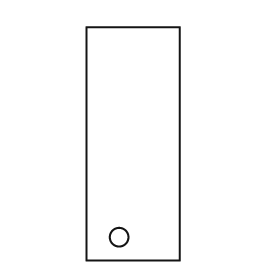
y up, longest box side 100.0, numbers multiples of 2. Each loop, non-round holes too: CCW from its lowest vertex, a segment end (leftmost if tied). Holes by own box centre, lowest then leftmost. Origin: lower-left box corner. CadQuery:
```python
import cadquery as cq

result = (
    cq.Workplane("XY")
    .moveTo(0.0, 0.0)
    .lineTo(40.0, 0.0)
    .lineTo(40.0, 100.0)
    .lineTo(0.0, 100.0)
    .close()
    .moveTo(14.0, 10.0)
    .circle(4.0)
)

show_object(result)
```